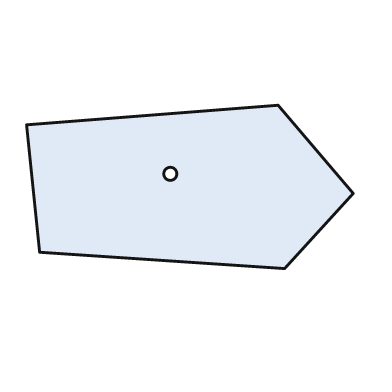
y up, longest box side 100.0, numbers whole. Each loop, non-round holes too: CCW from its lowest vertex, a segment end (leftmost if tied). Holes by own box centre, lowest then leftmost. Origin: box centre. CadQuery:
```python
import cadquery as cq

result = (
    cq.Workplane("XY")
    .moveTo(29.0, -25.0)
    .lineTo(50.0, -2.0)
    .lineTo(27.0, 25.0)
    .lineTo(-50.0, 19.0)
    .lineTo(-46.0, -20.0)
    .close()
    .moveTo(-6.0, 4.0)
    .circle(2.0)
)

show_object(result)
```